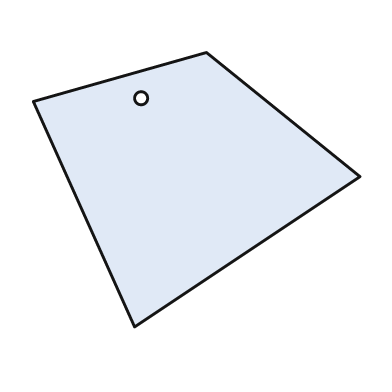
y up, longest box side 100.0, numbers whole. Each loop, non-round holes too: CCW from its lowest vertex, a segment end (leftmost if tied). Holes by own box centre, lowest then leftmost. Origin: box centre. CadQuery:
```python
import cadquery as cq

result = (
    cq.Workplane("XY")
    .moveTo(-19.0, -42.0)
    .lineTo(50.0, 4.0)
    .lineTo(3.0, 42.0)
    .lineTo(-50.0, 27.0)
    .close()
    .moveTo(-17.0, 28.0)
    .circle(2.0)
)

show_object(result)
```